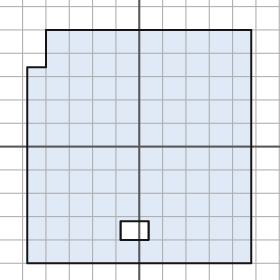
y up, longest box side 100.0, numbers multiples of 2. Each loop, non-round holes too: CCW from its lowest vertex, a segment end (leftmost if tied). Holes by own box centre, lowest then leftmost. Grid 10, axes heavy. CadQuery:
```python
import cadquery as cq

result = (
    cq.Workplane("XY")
    .moveTo(-48.0, -50.0)
    .lineTo(48.0, -50.0)
    .lineTo(48.0, 50.0)
    .lineTo(-40.0, 50.0)
    .lineTo(-40.0, 34.0)
    .lineTo(-48.0, 34.0)
    .close()
    .moveTo(-8.0, -40.0)
    .lineTo(4.0, -40.0)
    .lineTo(4.0, -32.0)
    .lineTo(-8.0, -32.0)
    .close()
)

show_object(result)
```